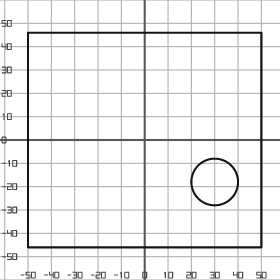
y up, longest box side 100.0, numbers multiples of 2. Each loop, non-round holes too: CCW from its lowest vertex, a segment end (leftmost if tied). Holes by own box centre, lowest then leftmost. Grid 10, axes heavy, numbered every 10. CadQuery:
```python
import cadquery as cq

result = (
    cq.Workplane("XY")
    .moveTo(-50.0, -46.0)
    .lineTo(50.0, -46.0)
    .lineTo(50.0, 46.0)
    .lineTo(-50.0, 46.0)
    .close()
    .moveTo(30.0, -18.0)
    .circle(10.0)
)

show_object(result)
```